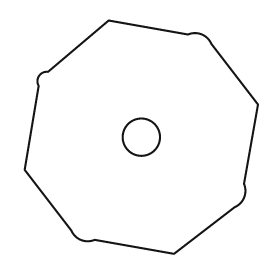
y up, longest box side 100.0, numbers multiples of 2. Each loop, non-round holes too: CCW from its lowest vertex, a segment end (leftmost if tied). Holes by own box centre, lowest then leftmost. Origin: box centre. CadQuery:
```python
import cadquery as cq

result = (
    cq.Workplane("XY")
    .moveTo(14.0, -50.0)
    .lineTo(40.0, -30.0)
    .threePointArc((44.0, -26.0), (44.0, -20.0))
    .lineTo(50.0, 14.0)
    .lineTo(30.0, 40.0)
    .threePointArc((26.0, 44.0), (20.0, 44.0))
    .lineTo(-14.0, 50.0)
    .lineTo(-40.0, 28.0)
    .threePointArc((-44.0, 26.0), (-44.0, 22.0))
    .lineTo(-50.0, -14.0)
    .lineTo(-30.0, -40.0)
    .threePointArc((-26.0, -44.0), (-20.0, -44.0))
    .close()
    .moveTo(0.0, 0.0)
    .circle(8.0)
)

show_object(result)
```